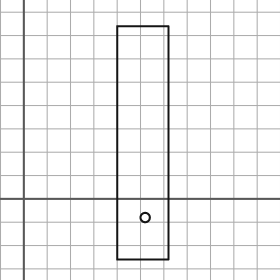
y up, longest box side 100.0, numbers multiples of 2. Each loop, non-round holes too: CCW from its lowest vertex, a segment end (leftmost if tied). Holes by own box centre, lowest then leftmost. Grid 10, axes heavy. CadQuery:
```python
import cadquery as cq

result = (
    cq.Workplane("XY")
    .moveTo(40.0, -26.0)
    .lineTo(62.0, -26.0)
    .lineTo(62.0, 74.0)
    .lineTo(40.0, 74.0)
    .close()
    .moveTo(52.0, -8.0)
    .circle(2.0)
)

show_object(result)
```